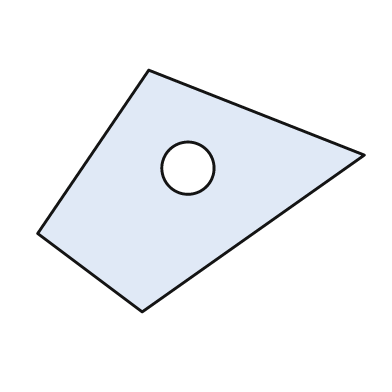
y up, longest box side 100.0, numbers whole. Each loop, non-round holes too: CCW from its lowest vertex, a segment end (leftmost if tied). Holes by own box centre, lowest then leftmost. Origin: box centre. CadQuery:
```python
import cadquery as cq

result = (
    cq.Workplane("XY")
    .moveTo(-18.0, -37.0)
    .lineTo(50.0, 11.0)
    .lineTo(-16.0, 37.0)
    .lineTo(-50.0, -13.0)
    .close()
    .moveTo(-4.0, 7.0)
    .circle(8.0)
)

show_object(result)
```